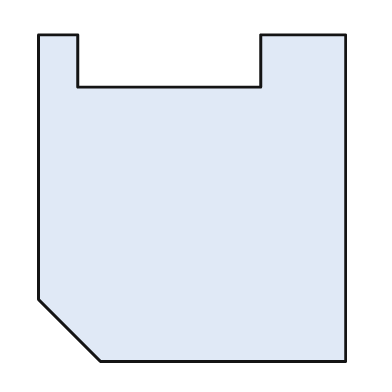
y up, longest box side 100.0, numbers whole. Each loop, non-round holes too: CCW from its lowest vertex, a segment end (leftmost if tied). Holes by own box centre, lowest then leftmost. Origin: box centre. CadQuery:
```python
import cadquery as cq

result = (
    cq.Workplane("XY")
    .moveTo(-28.0, -50.0)
    .lineTo(47.0, -50.0)
    .lineTo(47.0, 50.0)
    .lineTo(21.0, 50.0)
    .lineTo(21.0, 34.0)
    .lineTo(-35.0, 34.0)
    .lineTo(-35.0, 50.0)
    .lineTo(-47.0, 50.0)
    .lineTo(-47.0, -31.0)
    .close()
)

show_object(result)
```